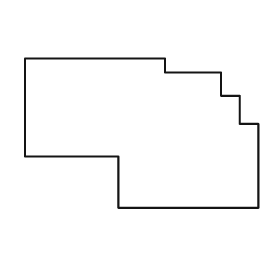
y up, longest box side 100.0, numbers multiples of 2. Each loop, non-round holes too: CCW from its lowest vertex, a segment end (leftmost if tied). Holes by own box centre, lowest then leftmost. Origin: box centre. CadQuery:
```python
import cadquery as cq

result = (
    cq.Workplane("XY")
    .moveTo(-10.0, -32.0)
    .lineTo(50.0, -32.0)
    .lineTo(50.0, 4.0)
    .lineTo(42.0, 4.0)
    .lineTo(42.0, 16.0)
    .lineTo(34.0, 16.0)
    .lineTo(34.0, 26.0)
    .lineTo(10.0, 26.0)
    .lineTo(10.0, 32.0)
    .lineTo(-50.0, 32.0)
    .lineTo(-50.0, -10.0)
    .lineTo(-10.0, -10.0)
    .close()
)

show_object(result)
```